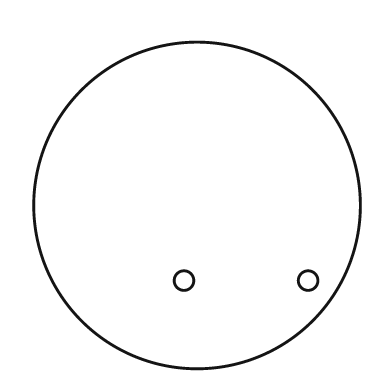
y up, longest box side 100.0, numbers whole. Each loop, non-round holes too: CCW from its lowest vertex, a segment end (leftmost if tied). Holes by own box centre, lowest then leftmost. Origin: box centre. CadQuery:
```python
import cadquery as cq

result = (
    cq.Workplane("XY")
    .moveTo(0.0, 0.0)
    .circle(50.0)
    .moveTo(-4.0, -23.0)
    .circle(3.0)
    .moveTo(34.0, -23.0)
    .circle(3.0)
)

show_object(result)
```